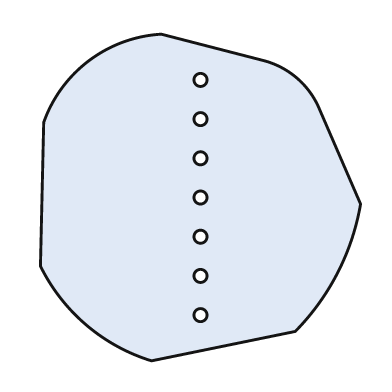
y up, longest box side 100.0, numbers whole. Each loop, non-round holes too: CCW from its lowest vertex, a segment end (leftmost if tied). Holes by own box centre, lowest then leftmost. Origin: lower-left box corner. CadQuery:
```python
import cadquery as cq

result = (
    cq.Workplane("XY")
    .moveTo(34.0, 0.0)
    .lineTo(78.0, 9.0)
    .threePointArc((91.0, 27.0), (98.0, 48.0))
    .lineTo(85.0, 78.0)
    .threePointArc((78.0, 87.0), (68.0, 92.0))
    .lineTo(37.0, 100.0)
    .threePointArc((15.0, 92.0), (1.0, 73.0))
    .lineTo(0.0, 29.0)
    .threePointArc((14.0, 11.0), (34.0, 0.0))
    .close()
    .moveTo(49.0, 14.0)
    .circle(2.0)
    .moveTo(49.0, 26.0)
    .circle(2.0)
    .moveTo(49.0, 38.0)
    .circle(2.0)
    .moveTo(49.0, 50.0)
    .circle(2.0)
    .moveTo(49.0, 62.0)
    .circle(2.0)
    .moveTo(49.0, 74.0)
    .circle(2.0)
    .moveTo(49.0, 86.0)
    .circle(2.0)
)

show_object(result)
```